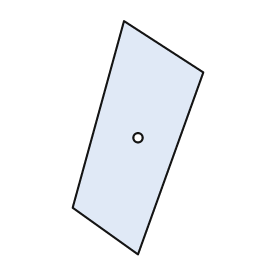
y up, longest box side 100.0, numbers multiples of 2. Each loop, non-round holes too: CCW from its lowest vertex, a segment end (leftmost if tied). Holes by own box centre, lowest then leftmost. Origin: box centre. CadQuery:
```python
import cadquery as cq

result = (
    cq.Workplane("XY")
    .moveTo(0.0, -50.0)
    .lineTo(28.0, 28.0)
    .lineTo(-6.0, 50.0)
    .lineTo(-28.0, -30.0)
    .close()
    .moveTo(0.0, 0.0)
    .circle(2.0)
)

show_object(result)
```